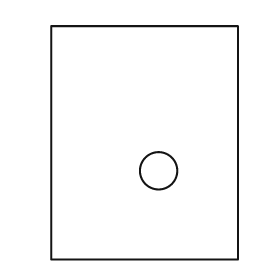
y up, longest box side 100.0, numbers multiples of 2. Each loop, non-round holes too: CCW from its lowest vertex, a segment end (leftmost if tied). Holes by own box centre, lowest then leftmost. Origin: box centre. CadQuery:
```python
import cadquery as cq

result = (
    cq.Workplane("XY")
    .moveTo(-40.0, -50.0)
    .lineTo(40.0, -50.0)
    .lineTo(40.0, 50.0)
    .lineTo(-40.0, 50.0)
    .close()
    .moveTo(6.0, -12.0)
    .circle(8.0)
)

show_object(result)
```